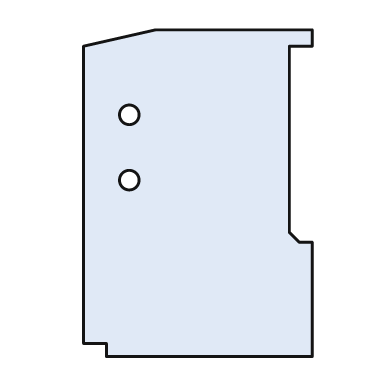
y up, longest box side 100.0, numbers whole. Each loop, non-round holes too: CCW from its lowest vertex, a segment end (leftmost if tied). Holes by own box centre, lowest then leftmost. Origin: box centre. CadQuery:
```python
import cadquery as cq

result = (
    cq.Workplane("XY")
    .moveTo(-28.0, -50.0)
    .lineTo(35.0, -50.0)
    .lineTo(35.0, -15.0)
    .lineTo(31.0, -15.0)
    .lineTo(28.0, -12.0)
    .lineTo(28.0, 45.0)
    .lineTo(35.0, 45.0)
    .lineTo(35.0, 50.0)
    .lineTo(-13.0, 50.0)
    .lineTo(-35.0, 45.0)
    .lineTo(-35.0, -46.0)
    .lineTo(-28.0, -46.0)
    .close()
    .moveTo(-21.0, 4.0)
    .circle(3.0)
    .moveTo(-21.0, 24.0)
    .circle(3.0)
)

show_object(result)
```